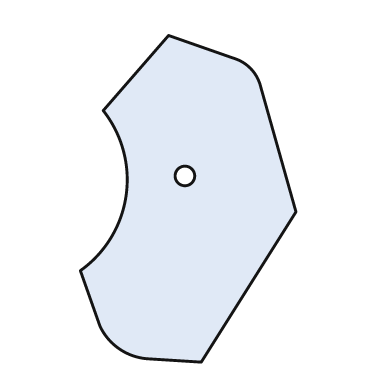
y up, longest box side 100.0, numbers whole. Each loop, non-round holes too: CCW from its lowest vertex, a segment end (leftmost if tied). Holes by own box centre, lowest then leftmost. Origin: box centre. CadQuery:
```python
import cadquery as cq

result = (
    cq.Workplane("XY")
    .moveTo(4.0, -50.0)
    .lineTo(33.0, -4.0)
    .lineTo(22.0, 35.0)
    .threePointArc((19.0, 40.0), (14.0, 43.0))
    .lineTo(-6.0, 50.0)
    .lineTo(-26.0, 27.0)
    .threePointArc((-19.0, 1.0), (-33.0, -22.0))
    .lineTo(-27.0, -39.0)
    .threePointArc((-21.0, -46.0), (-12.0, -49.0))
    .close()
    .moveTo(-1.0, 7.0)
    .circle(3.0)
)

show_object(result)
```